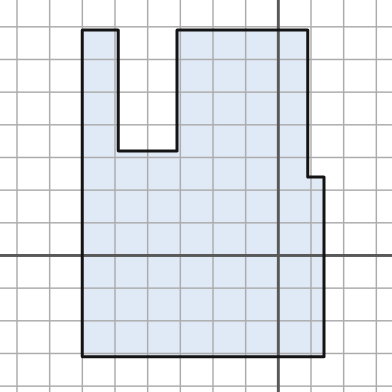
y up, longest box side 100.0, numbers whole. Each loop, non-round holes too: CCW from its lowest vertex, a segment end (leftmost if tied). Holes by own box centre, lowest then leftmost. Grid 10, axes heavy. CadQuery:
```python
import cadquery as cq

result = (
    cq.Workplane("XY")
    .moveTo(-60.0, -31.0)
    .lineTo(14.0, -31.0)
    .lineTo(14.0, 24.0)
    .lineTo(9.0, 24.0)
    .lineTo(9.0, 69.0)
    .lineTo(-31.0, 69.0)
    .lineTo(-31.0, 32.0)
    .lineTo(-49.0, 32.0)
    .lineTo(-49.0, 69.0)
    .lineTo(-60.0, 69.0)
    .close()
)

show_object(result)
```